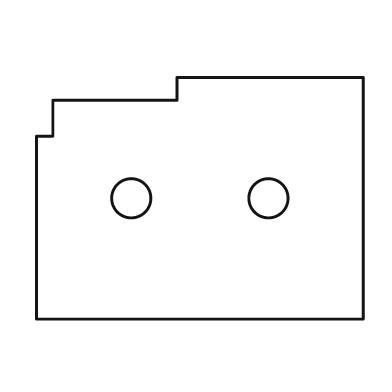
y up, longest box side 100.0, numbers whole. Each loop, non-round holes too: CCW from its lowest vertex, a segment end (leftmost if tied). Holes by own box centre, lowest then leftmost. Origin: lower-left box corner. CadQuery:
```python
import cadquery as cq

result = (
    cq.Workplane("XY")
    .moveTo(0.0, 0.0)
    .lineTo(100.0, 0.0)
    .lineTo(100.0, 74.0)
    .lineTo(43.0, 74.0)
    .lineTo(43.0, 67.0)
    .lineTo(5.0, 67.0)
    .lineTo(5.0, 56.0)
    .lineTo(0.0, 56.0)
    .close()
    .moveTo(29.0, 37.0)
    .circle(6.0)
    .moveTo(71.0, 37.0)
    .circle(6.0)
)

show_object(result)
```